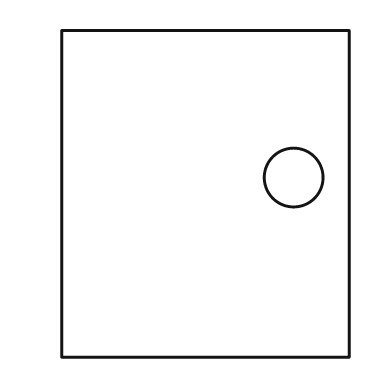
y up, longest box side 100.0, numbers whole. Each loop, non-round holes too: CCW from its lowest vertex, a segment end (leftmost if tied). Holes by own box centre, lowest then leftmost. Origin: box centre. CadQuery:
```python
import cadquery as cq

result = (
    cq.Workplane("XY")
    .moveTo(-44.0, -50.0)
    .lineTo(44.0, -50.0)
    .lineTo(44.0, 50.0)
    .lineTo(-44.0, 50.0)
    .close()
    .moveTo(27.0, 5.0)
    .circle(9.0)
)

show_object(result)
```